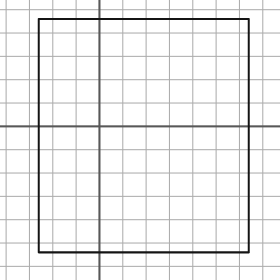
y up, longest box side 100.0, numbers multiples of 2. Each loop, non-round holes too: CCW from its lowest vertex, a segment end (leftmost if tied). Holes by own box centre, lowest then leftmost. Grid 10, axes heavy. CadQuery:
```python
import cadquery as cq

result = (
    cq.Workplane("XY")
    .moveTo(-26.0, -54.0)
    .lineTo(64.0, -54.0)
    .lineTo(64.0, 46.0)
    .lineTo(-26.0, 46.0)
    .close()
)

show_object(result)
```